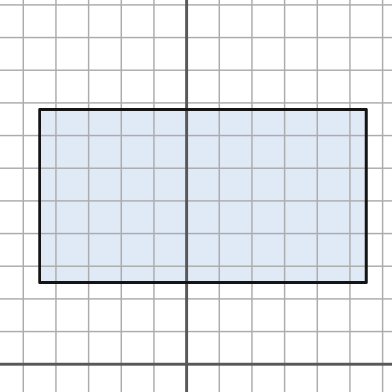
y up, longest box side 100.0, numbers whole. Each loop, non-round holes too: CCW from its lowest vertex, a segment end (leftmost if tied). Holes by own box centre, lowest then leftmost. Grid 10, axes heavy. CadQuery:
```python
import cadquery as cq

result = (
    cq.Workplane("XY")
    .moveTo(-45.0, 25.0)
    .lineTo(55.0, 25.0)
    .lineTo(55.0, 78.0)
    .lineTo(-45.0, 78.0)
    .close()
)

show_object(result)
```